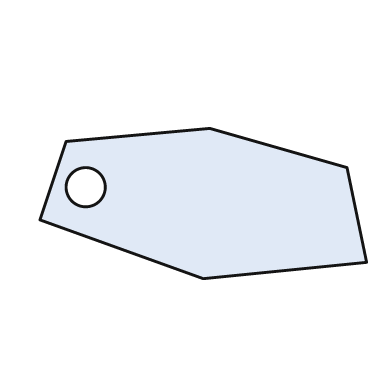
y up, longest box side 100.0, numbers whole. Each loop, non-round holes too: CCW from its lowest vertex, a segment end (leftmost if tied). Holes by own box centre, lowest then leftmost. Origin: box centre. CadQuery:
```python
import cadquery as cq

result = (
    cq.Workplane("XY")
    .moveTo(0.0, -23.0)
    .lineTo(50.0, -18.0)
    .lineTo(44.0, 11.0)
    .lineTo(2.0, 23.0)
    .lineTo(-42.0, 19.0)
    .lineTo(-50.0, -5.0)
    .close()
    .moveTo(-36.0, 5.0)
    .circle(6.0)
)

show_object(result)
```